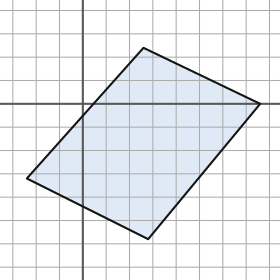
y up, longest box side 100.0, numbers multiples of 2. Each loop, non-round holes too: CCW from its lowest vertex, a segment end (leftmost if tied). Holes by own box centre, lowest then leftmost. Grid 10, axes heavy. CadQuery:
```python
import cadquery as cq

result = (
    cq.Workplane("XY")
    .moveTo(28.0, -58.0)
    .lineTo(76.0, 0.0)
    .lineTo(26.0, 24.0)
    .lineTo(-24.0, -32.0)
    .close()
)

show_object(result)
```